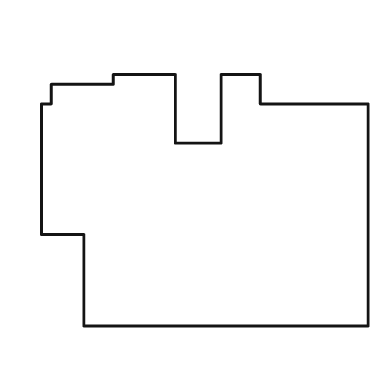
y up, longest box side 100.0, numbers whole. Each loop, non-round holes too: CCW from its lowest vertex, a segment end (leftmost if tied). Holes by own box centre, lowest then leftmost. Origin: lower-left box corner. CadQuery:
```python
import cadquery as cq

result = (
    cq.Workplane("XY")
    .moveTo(13.0, 0.0)
    .lineTo(100.0, 0.0)
    .lineTo(100.0, 68.0)
    .lineTo(67.0, 68.0)
    .lineTo(67.0, 77.0)
    .lineTo(55.0, 77.0)
    .lineTo(55.0, 56.0)
    .lineTo(41.0, 56.0)
    .lineTo(41.0, 77.0)
    .lineTo(22.0, 77.0)
    .lineTo(22.0, 74.0)
    .lineTo(3.0, 74.0)
    .lineTo(3.0, 68.0)
    .lineTo(0.0, 68.0)
    .lineTo(0.0, 28.0)
    .lineTo(13.0, 28.0)
    .close()
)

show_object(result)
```